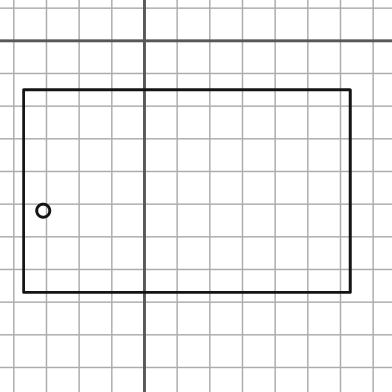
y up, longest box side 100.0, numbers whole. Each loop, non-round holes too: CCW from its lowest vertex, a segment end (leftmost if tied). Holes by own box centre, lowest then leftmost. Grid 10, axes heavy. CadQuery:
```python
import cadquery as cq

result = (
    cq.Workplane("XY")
    .moveTo(-37.0, -77.0)
    .lineTo(63.0, -77.0)
    .lineTo(63.0, -15.0)
    .lineTo(-37.0, -15.0)
    .close()
    .moveTo(-31.0, -52.0)
    .circle(2.0)
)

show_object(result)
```